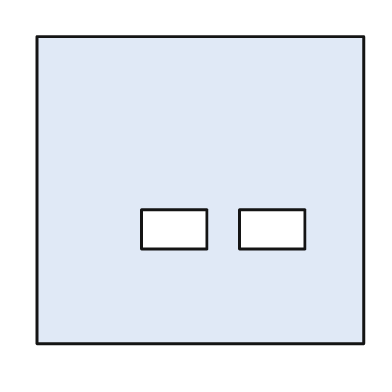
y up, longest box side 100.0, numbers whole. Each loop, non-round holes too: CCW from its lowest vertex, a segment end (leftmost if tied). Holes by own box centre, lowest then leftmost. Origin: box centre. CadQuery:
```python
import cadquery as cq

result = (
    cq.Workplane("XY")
    .moveTo(-50.0, -47.0)
    .lineTo(50.0, -47.0)
    .lineTo(50.0, 47.0)
    .lineTo(-50.0, 47.0)
    .close()
    .moveTo(-18.0, -18.0)
    .lineTo(2.0, -18.0)
    .lineTo(2.0, -6.0)
    .lineTo(-18.0, -6.0)
    .close()
    .moveTo(12.0, -18.0)
    .lineTo(32.0, -18.0)
    .lineTo(32.0, -6.0)
    .lineTo(12.0, -6.0)
    .close()
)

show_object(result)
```